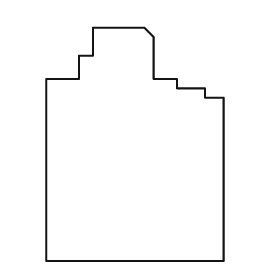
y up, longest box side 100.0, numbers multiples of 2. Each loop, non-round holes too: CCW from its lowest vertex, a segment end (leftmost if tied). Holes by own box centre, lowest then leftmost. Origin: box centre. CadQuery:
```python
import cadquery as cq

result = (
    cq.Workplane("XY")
    .moveTo(-38.0, -50.0)
    .lineTo(38.0, -50.0)
    .lineTo(38.0, 20.0)
    .lineTo(30.0, 20.0)
    .lineTo(30.0, 24.0)
    .lineTo(18.0, 24.0)
    .lineTo(18.0, 28.0)
    .lineTo(8.0, 28.0)
    .lineTo(8.0, 46.0)
    .lineTo(4.0, 50.0)
    .lineTo(-18.0, 50.0)
    .lineTo(-18.0, 38.0)
    .lineTo(-24.0, 38.0)
    .lineTo(-24.0, 28.0)
    .lineTo(-38.0, 28.0)
    .close()
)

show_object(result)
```